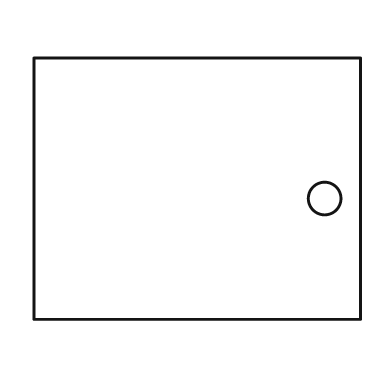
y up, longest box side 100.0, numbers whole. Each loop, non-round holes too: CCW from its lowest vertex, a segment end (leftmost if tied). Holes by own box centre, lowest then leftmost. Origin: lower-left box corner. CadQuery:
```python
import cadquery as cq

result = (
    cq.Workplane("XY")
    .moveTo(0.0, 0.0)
    .lineTo(100.0, 0.0)
    .lineTo(100.0, 80.0)
    .lineTo(0.0, 80.0)
    .close()
    .moveTo(89.0, 37.0)
    .circle(5.0)
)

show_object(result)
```